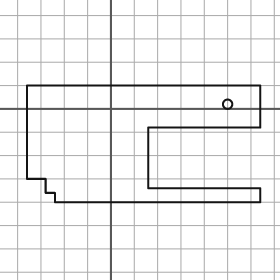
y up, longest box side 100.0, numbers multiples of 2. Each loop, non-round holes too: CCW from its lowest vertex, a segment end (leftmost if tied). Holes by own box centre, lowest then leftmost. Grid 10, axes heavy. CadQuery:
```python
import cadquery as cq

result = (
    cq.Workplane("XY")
    .moveTo(-24.0, -40.0)
    .lineTo(64.0, -40.0)
    .lineTo(64.0, -34.0)
    .lineTo(16.0, -34.0)
    .lineTo(16.0, -8.0)
    .lineTo(64.0, -8.0)
    .lineTo(64.0, 10.0)
    .lineTo(-36.0, 10.0)
    .lineTo(-36.0, -30.0)
    .lineTo(-28.0, -30.0)
    .lineTo(-28.0, -36.0)
    .lineTo(-24.0, -36.0)
    .close()
    .moveTo(50.0, 2.0)
    .circle(2.0)
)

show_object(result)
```